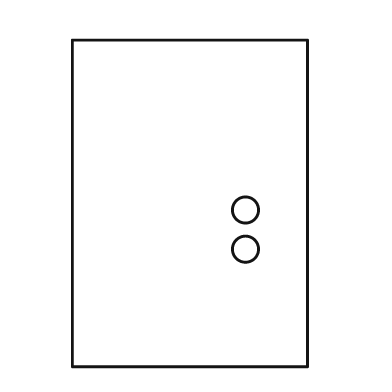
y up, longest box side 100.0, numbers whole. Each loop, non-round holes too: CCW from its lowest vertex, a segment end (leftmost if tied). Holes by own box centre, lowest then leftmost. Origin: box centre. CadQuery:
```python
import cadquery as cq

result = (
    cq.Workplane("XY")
    .moveTo(-36.0, -50.0)
    .lineTo(36.0, -50.0)
    .lineTo(36.0, 50.0)
    .lineTo(-36.0, 50.0)
    .close()
    .moveTo(17.0, -14.0)
    .circle(4.0)
    .moveTo(17.0, -2.0)
    .circle(4.0)
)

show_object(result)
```